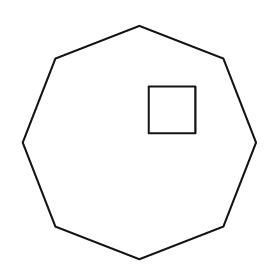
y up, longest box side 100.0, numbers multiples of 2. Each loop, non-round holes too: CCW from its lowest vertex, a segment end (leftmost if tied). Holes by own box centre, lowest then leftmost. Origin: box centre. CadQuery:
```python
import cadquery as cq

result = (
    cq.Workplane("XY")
    .moveTo(0.0, -50.0)
    .lineTo(36.0, -36.0)
    .lineTo(50.0, 0.0)
    .lineTo(36.0, 36.0)
    .lineTo(0.0, 50.0)
    .lineTo(-36.0, 36.0)
    .lineTo(-50.0, 0.0)
    .lineTo(-36.0, -36.0)
    .close()
    .moveTo(4.0, 4.0)
    .lineTo(24.0, 4.0)
    .lineTo(24.0, 24.0)
    .lineTo(4.0, 24.0)
    .close()
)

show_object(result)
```